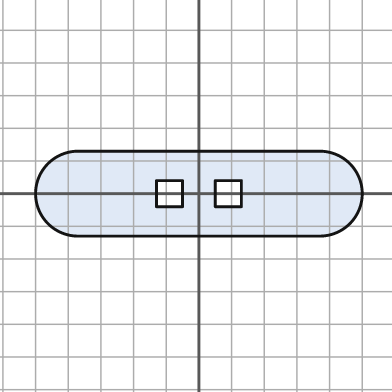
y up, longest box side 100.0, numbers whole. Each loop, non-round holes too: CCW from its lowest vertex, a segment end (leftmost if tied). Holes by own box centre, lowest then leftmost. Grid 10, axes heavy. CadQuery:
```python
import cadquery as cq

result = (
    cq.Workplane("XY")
    .moveTo(-37.0, -13.0)
    .lineTo(37.0, -13.0)
    .threePointArc((50.0, 0.0), (37.0, 13.0))
    .lineTo(-37.0, 13.0)
    .threePointArc((-50.0, 0.0), (-37.0, -13.0))
    .close()
    .moveTo(-13.0, -4.0)
    .lineTo(-5.0, -4.0)
    .lineTo(-5.0, 4.0)
    .lineTo(-13.0, 4.0)
    .close()
    .moveTo(5.0, -4.0)
    .lineTo(13.0, -4.0)
    .lineTo(13.0, 4.0)
    .lineTo(5.0, 4.0)
    .close()
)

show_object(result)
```